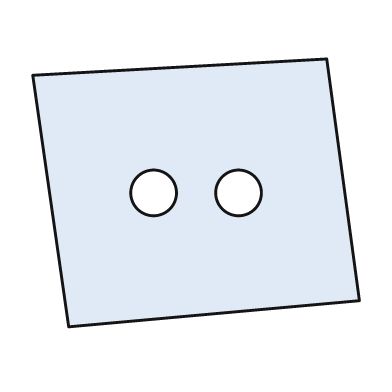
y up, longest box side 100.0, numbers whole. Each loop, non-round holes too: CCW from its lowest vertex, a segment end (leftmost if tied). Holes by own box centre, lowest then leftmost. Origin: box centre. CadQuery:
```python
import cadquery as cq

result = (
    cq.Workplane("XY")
    .moveTo(-39.0, -41.0)
    .lineTo(50.0, -33.0)
    .lineTo(40.0, 41.0)
    .lineTo(-50.0, 36.0)
    .close()
    .moveTo(-13.0, 0.0)
    .circle(7.0)
    .moveTo(13.0, 0.0)
    .circle(7.0)
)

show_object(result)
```